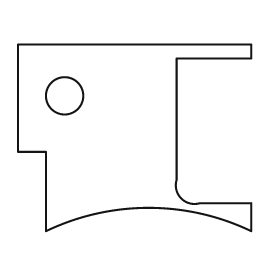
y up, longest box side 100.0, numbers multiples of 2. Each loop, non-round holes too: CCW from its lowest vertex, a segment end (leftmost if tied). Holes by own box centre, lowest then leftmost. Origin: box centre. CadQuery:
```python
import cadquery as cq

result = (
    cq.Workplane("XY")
    .moveTo(-38.0, -40.0)
    .threePointArc((6.0, -30.0), (50.0, -40.0))
    .lineTo(50.0, -28.0)
    .lineTo(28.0, -28.0)
    .threePointArc((20.0, -26.0), (18.0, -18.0))
    .lineTo(18.0, 34.0)
    .lineTo(50.0, 34.0)
    .lineTo(50.0, 40.0)
    .lineTo(-50.0, 40.0)
    .lineTo(-50.0, -6.0)
    .lineTo(-38.0, -6.0)
    .close()
    .moveTo(-30.0, 18.0)
    .circle(8.0)
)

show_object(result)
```